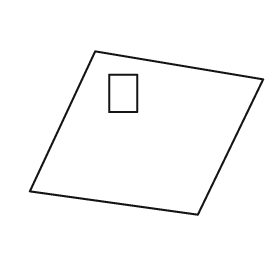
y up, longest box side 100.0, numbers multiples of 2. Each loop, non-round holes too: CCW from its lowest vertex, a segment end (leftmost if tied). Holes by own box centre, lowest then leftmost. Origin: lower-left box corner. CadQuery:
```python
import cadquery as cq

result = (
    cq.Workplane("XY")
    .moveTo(72.0, 0.0)
    .lineTo(100.0, 58.0)
    .lineTo(28.0, 70.0)
    .lineTo(0.0, 10.0)
    .close()
    .moveTo(34.0, 44.0)
    .lineTo(46.0, 44.0)
    .lineTo(46.0, 60.0)
    .lineTo(34.0, 60.0)
    .close()
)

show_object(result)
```